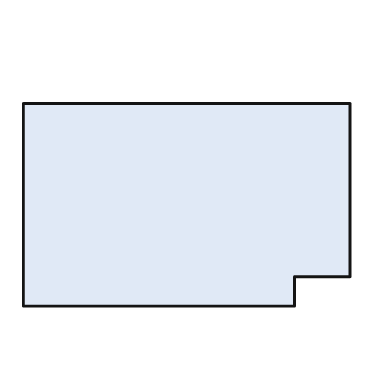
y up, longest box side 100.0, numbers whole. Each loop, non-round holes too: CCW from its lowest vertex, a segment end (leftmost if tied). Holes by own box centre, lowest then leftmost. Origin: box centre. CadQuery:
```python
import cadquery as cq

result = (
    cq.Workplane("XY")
    .moveTo(-50.0, -31.0)
    .lineTo(33.0, -31.0)
    .lineTo(33.0, -22.0)
    .lineTo(50.0, -22.0)
    .lineTo(50.0, 31.0)
    .lineTo(-50.0, 31.0)
    .close()
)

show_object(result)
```